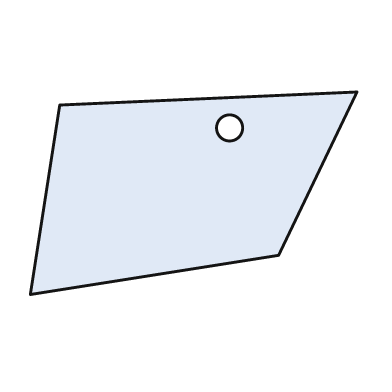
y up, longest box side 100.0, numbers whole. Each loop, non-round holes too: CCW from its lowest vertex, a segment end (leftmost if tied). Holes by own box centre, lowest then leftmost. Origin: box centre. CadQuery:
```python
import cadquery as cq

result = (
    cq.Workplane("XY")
    .moveTo(-50.0, -31.0)
    .lineTo(26.0, -19.0)
    .lineTo(50.0, 31.0)
    .lineTo(-41.0, 27.0)
    .close()
    .moveTo(11.0, 20.0)
    .circle(4.0)
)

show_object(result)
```